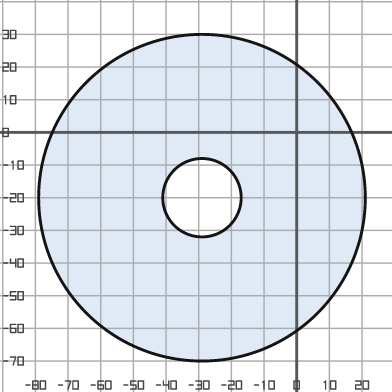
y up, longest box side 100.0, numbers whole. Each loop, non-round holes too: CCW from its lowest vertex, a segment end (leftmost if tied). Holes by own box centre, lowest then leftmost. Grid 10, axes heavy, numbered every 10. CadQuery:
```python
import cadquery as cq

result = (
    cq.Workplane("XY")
    .moveTo(-29.0, -20.0)
    .circle(50.0)
    .moveTo(-29.0, -20.0)
    .circle(12.0)
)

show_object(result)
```